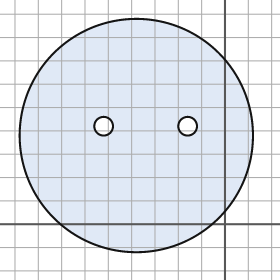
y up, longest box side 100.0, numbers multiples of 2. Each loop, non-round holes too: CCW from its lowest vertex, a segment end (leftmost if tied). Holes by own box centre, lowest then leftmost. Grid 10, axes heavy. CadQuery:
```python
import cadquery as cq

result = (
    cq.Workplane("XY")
    .moveTo(-38.0, 38.0)
    .circle(50.0)
    .moveTo(-52.0, 42.0)
    .circle(4.0)
    .moveTo(-16.0, 42.0)
    .circle(4.0)
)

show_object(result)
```